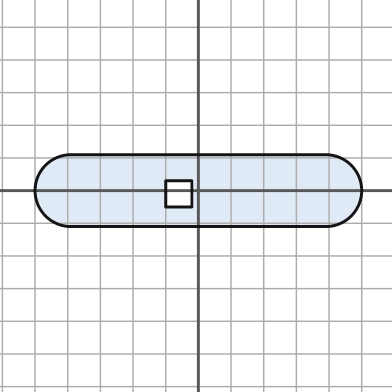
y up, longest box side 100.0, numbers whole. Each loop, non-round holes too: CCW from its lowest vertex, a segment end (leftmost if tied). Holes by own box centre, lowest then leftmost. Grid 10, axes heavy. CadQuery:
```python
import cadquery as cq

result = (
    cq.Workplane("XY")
    .moveTo(-39.0, -11.0)
    .lineTo(39.0, -11.0)
    .threePointArc((50.0, 0.0), (39.0, 11.0))
    .lineTo(-39.0, 11.0)
    .threePointArc((-50.0, 0.0), (-39.0, -11.0))
    .close()
    .moveTo(-10.0, -5.0)
    .lineTo(-2.0, -5.0)
    .lineTo(-2.0, 3.0)
    .lineTo(-10.0, 3.0)
    .close()
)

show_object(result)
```